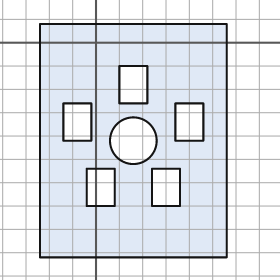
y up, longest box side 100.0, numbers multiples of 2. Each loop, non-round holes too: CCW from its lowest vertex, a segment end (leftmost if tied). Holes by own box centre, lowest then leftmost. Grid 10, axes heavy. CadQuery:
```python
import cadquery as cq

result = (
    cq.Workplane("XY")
    .moveTo(-24.0, -92.0)
    .lineTo(56.0, -92.0)
    .lineTo(56.0, 8.0)
    .lineTo(-24.0, 8.0)
    .close()
    .moveTo(-4.0, -70.0)
    .lineTo(8.0, -70.0)
    .lineTo(8.0, -54.0)
    .lineTo(-4.0, -54.0)
    .close()
    .moveTo(24.0, -70.0)
    .lineTo(36.0, -70.0)
    .lineTo(36.0, -54.0)
    .lineTo(24.0, -54.0)
    .close()
    .moveTo(16.0, -42.0)
    .circle(10.0)
    .moveTo(-14.0, -42.0)
    .lineTo(-2.0, -42.0)
    .lineTo(-2.0, -26.0)
    .lineTo(-14.0, -26.0)
    .close()
    .moveTo(34.0, -42.0)
    .lineTo(46.0, -42.0)
    .lineTo(46.0, -26.0)
    .lineTo(34.0, -26.0)
    .close()
    .moveTo(10.0, -26.0)
    .lineTo(22.0, -26.0)
    .lineTo(22.0, -10.0)
    .lineTo(10.0, -10.0)
    .close()
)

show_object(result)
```